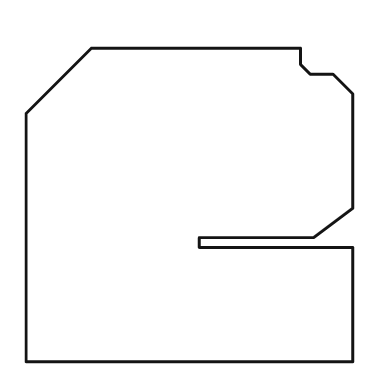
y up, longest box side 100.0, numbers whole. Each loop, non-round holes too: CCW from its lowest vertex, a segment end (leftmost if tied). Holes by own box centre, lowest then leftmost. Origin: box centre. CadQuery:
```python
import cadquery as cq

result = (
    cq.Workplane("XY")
    .moveTo(-50.0, -48.0)
    .lineTo(50.0, -48.0)
    .lineTo(50.0, -13.0)
    .lineTo(3.0, -13.0)
    .lineTo(3.0, -10.0)
    .lineTo(38.0, -10.0)
    .lineTo(50.0, -1.0)
    .lineTo(50.0, 34.0)
    .lineTo(44.0, 40.0)
    .lineTo(37.0, 40.0)
    .lineTo(34.0, 43.0)
    .lineTo(34.0, 48.0)
    .lineTo(-30.0, 48.0)
    .lineTo(-50.0, 28.0)
    .close()
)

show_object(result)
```